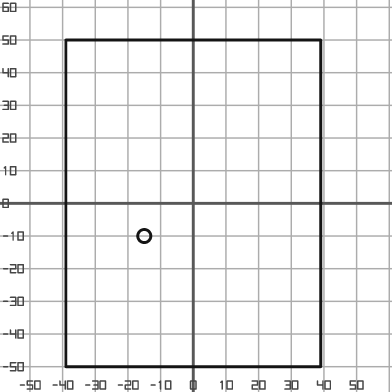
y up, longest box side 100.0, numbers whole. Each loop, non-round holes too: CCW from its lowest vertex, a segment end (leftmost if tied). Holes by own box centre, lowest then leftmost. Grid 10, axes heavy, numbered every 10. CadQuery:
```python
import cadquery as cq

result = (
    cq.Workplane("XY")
    .moveTo(-39.0, -50.0)
    .lineTo(39.0, -50.0)
    .lineTo(39.0, 50.0)
    .lineTo(-39.0, 50.0)
    .close()
    .moveTo(-15.0, -10.0)
    .circle(2.0)
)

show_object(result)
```